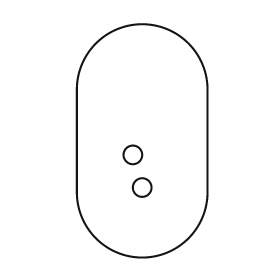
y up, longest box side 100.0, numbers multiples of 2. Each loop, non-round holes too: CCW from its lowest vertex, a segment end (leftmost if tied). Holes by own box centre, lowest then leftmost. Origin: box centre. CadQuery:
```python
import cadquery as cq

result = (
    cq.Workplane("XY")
    .moveTo(-28.0, -22.0)
    .threePointArc((0.0, -50.0), (28.0, -22.0))
    .lineTo(28.0, 22.0)
    .threePointArc((0.0, 50.0), (-28.0, 22.0))
    .close()
    .moveTo(0.0, -20.0)
    .circle(4.0)
    .moveTo(-4.0, -6.0)
    .circle(4.0)
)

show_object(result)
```